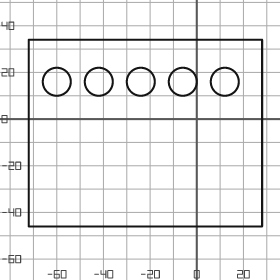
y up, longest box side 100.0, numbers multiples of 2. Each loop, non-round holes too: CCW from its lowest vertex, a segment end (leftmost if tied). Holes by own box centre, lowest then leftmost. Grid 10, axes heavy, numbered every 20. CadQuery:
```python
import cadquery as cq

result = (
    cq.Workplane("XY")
    .moveTo(-72.0, -46.0)
    .lineTo(28.0, -46.0)
    .lineTo(28.0, 34.0)
    .lineTo(-72.0, 34.0)
    .close()
    .moveTo(-60.0, 16.0)
    .circle(6.0)
    .moveTo(-42.0, 16.0)
    .circle(6.0)
    .moveTo(-24.0, 16.0)
    .circle(6.0)
    .moveTo(-6.0, 16.0)
    .circle(6.0)
    .moveTo(12.0, 16.0)
    .circle(6.0)
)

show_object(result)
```